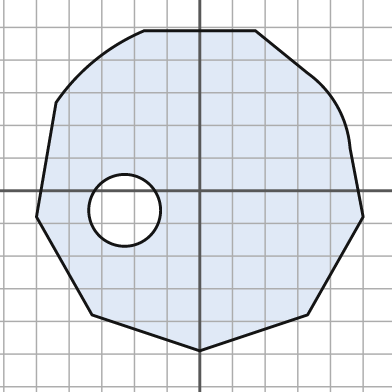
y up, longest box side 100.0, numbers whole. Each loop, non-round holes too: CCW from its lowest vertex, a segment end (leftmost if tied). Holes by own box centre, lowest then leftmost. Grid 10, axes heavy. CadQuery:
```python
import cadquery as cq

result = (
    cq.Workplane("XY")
    .moveTo(0.0, -49.0)
    .lineTo(33.0, -38.0)
    .lineTo(50.0, -8.0)
    .lineTo(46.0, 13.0)
    .threePointArc((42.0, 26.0), (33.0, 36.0))
    .lineTo(17.0, 49.0)
    .lineTo(-17.0, 49.0)
    .threePointArc((-32.0, 40.0), (-44.0, 27.0))
    .lineTo(-50.0, -8.0)
    .lineTo(-33.0, -38.0)
    .close()
    .moveTo(-23.0, -6.0)
    .circle(11.0)
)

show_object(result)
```